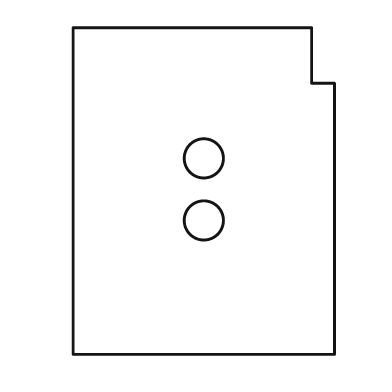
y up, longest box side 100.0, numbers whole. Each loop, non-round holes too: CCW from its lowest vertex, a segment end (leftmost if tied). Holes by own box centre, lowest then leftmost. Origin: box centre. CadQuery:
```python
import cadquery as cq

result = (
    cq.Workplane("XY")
    .moveTo(-40.0, -50.0)
    .lineTo(40.0, -50.0)
    .lineTo(40.0, 33.0)
    .lineTo(33.0, 33.0)
    .lineTo(33.0, 50.0)
    .lineTo(-40.0, 50.0)
    .close()
    .moveTo(0.0, -9.0)
    .circle(6.0)
    .moveTo(0.0, 10.0)
    .circle(6.0)
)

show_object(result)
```